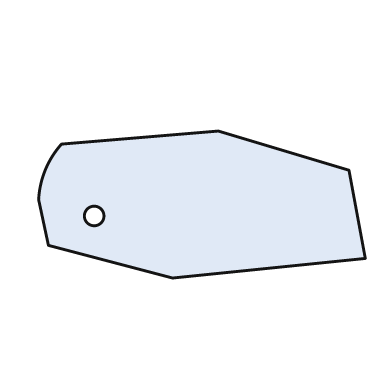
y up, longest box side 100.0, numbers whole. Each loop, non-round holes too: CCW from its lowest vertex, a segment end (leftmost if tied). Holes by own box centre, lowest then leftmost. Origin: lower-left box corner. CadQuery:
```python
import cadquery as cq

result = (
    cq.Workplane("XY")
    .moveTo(41.0, 0.0)
    .lineTo(100.0, 6.0)
    .lineTo(95.0, 33.0)
    .lineTo(55.0, 45.0)
    .lineTo(7.0, 41.0)
    .threePointArc((2.0, 33.0), (0.0, 24.0))
    .lineTo(3.0, 10.0)
    .close()
    .moveTo(17.0, 19.0)
    .circle(3.0)
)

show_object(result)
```